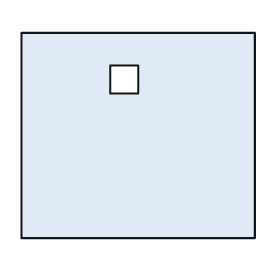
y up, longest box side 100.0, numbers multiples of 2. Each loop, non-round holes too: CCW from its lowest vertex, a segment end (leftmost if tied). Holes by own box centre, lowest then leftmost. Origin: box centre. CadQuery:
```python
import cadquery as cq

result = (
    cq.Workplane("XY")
    .moveTo(-50.0, -44.0)
    .lineTo(50.0, -44.0)
    .lineTo(50.0, 44.0)
    .lineTo(-50.0, 44.0)
    .close()
    .moveTo(-12.0, 18.0)
    .lineTo(0.0, 18.0)
    .lineTo(0.0, 30.0)
    .lineTo(-12.0, 30.0)
    .close()
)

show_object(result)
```